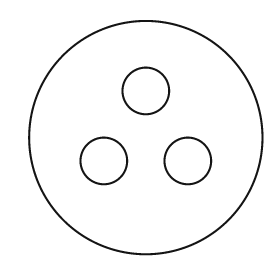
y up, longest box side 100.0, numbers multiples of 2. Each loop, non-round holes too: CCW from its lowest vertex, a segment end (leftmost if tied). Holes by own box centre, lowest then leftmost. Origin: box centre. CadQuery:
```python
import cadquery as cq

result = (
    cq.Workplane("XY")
    .moveTo(0.0, 0.0)
    .circle(50.0)
    .moveTo(-18.0, -10.0)
    .circle(10.0)
    .moveTo(18.0, -10.0)
    .circle(10.0)
    .moveTo(0.0, 20.0)
    .circle(10.0)
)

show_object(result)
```